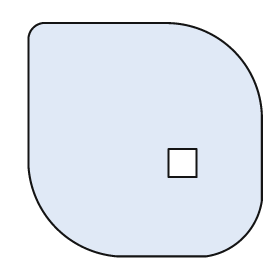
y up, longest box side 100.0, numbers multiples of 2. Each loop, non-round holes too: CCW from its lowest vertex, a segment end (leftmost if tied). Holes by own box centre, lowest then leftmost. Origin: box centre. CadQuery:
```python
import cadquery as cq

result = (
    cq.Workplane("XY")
    .moveTo(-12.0, -50.0)
    .lineTo(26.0, -50.0)
    .threePointArc((42.0, -42.0), (50.0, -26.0))
    .lineTo(50.0, 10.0)
    .threePointArc((38.0, 38.0), (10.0, 50.0))
    .lineTo(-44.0, 50.0)
    .threePointArc((-48.0, 48.0), (-50.0, 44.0))
    .lineTo(-50.0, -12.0)
    .threePointArc((-38.0, -38.0), (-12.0, -50.0))
    .close()
    .moveTo(10.0, -16.0)
    .lineTo(22.0, -16.0)
    .lineTo(22.0, -4.0)
    .lineTo(10.0, -4.0)
    .close()
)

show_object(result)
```